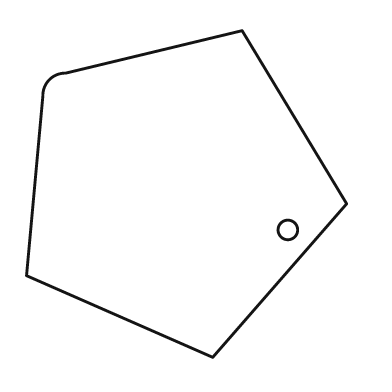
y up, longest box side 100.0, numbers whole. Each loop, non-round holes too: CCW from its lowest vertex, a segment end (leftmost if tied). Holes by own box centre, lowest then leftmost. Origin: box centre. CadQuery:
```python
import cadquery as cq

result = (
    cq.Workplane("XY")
    .moveTo(8.0, -50.0)
    .lineTo(49.0, -3.0)
    .lineTo(17.0, 50.0)
    .lineTo(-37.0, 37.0)
    .threePointArc((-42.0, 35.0), (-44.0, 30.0))
    .lineTo(-49.0, -25.0)
    .close()
    .moveTo(31.0, -11.0)
    .circle(3.0)
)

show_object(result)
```